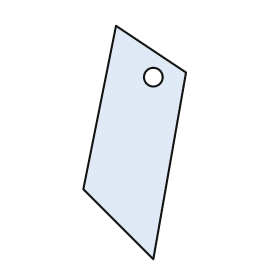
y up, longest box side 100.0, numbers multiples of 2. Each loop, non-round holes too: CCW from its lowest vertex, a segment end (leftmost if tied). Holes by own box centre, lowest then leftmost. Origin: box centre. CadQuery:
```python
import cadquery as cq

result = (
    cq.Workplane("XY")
    .moveTo(8.0, -50.0)
    .lineTo(22.0, 30.0)
    .lineTo(-8.0, 50.0)
    .lineTo(-22.0, -20.0)
    .close()
    .moveTo(8.0, 28.0)
    .circle(4.0)
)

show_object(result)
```